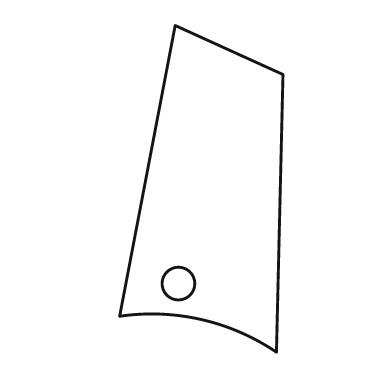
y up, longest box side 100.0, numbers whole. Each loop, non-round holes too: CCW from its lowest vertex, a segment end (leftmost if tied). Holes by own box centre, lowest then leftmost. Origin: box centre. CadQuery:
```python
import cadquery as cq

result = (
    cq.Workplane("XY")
    .moveTo(23.0, -50.0)
    .lineTo(25.0, 35.0)
    .lineTo(-8.0, 50.0)
    .lineTo(-25.0, -39.0)
    .threePointArc((0.0, -40.0), (23.0, -50.0))
    .close()
    .moveTo(-7.0, -29.0)
    .circle(5.0)
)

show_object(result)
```